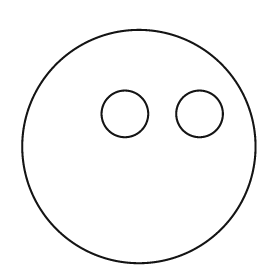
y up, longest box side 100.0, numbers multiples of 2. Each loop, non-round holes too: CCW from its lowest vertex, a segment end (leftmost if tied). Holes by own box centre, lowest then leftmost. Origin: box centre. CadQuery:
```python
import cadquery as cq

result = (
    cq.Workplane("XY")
    .moveTo(0.0, 0.0)
    .circle(50.0)
    .moveTo(-6.0, 14.0)
    .circle(10.0)
    .moveTo(26.0, 14.0)
    .circle(10.0)
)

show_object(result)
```